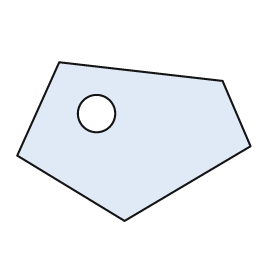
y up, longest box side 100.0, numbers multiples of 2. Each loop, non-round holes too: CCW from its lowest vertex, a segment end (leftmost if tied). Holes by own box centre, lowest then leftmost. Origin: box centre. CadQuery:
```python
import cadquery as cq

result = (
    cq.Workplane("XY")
    .moveTo(-4.0, -34.0)
    .lineTo(50.0, -2.0)
    .lineTo(38.0, 26.0)
    .lineTo(-32.0, 34.0)
    .lineTo(-50.0, -6.0)
    .close()
    .moveTo(-16.0, 12.0)
    .circle(8.0)
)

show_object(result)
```